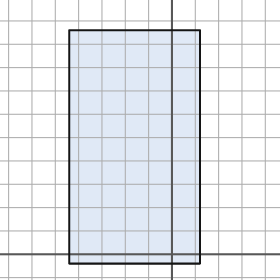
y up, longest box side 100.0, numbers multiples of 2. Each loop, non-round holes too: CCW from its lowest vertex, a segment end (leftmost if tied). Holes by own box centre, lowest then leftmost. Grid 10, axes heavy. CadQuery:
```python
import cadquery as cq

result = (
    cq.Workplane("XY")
    .moveTo(-44.0, -4.0)
    .lineTo(12.0, -4.0)
    .lineTo(12.0, 96.0)
    .lineTo(-44.0, 96.0)
    .close()
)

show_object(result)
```